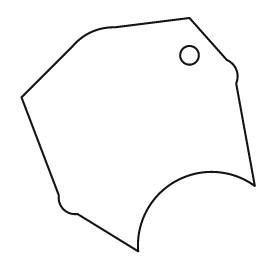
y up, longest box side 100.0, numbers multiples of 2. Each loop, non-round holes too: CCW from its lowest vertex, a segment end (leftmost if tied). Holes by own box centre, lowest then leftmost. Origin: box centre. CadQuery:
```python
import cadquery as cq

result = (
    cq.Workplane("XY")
    .moveTo(0.0, -50.0)
    .threePointArc((16.0, -20.0), (50.0, -22.0))
    .lineTo(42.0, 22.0)
    .threePointArc((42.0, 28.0), (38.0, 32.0))
    .lineTo(22.0, 50.0)
    .lineTo(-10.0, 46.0)
    .threePointArc((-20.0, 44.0), (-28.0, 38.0))
    .lineTo(-50.0, 16.0)
    .lineTo(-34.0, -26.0)
    .threePointArc((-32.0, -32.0), (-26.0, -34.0))
    .close()
    .moveTo(22.0, 34.0)
    .circle(4.0)
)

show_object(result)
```